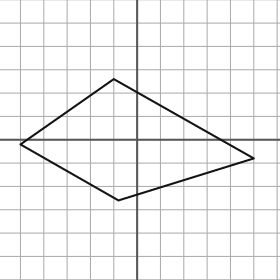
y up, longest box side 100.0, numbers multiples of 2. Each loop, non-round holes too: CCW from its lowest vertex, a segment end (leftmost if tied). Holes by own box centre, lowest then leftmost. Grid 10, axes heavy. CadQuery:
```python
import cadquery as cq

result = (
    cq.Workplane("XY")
    .moveTo(-8.0, -26.0)
    .lineTo(50.0, -8.0)
    .lineTo(-10.0, 26.0)
    .lineTo(-50.0, -2.0)
    .close()
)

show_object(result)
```